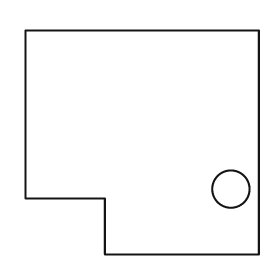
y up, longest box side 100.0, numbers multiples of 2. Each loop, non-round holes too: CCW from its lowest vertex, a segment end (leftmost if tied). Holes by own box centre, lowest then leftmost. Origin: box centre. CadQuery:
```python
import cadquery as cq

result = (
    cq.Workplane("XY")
    .moveTo(-16.0, -48.0)
    .lineTo(50.0, -48.0)
    .lineTo(50.0, 48.0)
    .lineTo(-50.0, 48.0)
    .lineTo(-50.0, -24.0)
    .lineTo(-16.0, -24.0)
    .close()
    .moveTo(38.0, -20.0)
    .circle(8.0)
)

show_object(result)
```